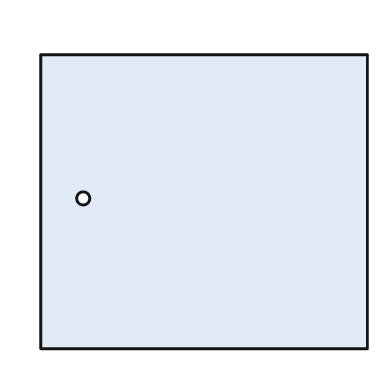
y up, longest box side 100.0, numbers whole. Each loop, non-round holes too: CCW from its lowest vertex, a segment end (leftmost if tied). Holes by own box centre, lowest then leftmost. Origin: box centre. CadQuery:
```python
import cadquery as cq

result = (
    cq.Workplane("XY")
    .moveTo(-50.0, -45.0)
    .lineTo(50.0, -45.0)
    .lineTo(50.0, 45.0)
    .lineTo(-50.0, 45.0)
    .close()
    .moveTo(-37.0, 1.0)
    .circle(2.0)
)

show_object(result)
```